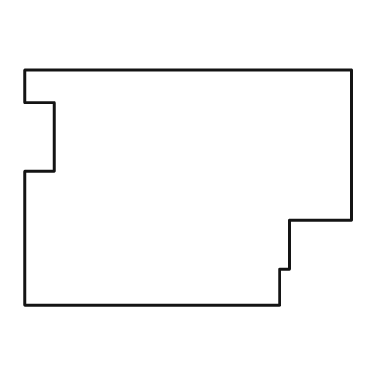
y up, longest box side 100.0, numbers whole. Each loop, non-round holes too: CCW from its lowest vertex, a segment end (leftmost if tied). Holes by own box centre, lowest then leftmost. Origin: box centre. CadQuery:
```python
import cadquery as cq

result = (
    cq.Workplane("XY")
    .moveTo(-50.0, -36.0)
    .lineTo(28.0, -36.0)
    .lineTo(28.0, -25.0)
    .lineTo(31.0, -25.0)
    .lineTo(31.0, -10.0)
    .lineTo(50.0, -10.0)
    .lineTo(50.0, 36.0)
    .lineTo(-50.0, 36.0)
    .lineTo(-50.0, 26.0)
    .lineTo(-41.0, 26.0)
    .lineTo(-41.0, 5.0)
    .lineTo(-50.0, 5.0)
    .close()
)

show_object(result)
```